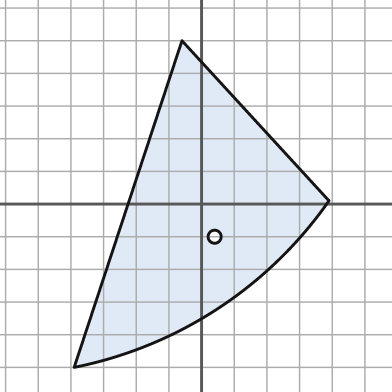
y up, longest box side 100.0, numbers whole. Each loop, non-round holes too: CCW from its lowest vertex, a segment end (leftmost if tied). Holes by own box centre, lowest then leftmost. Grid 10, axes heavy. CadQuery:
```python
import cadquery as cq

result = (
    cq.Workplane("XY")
    .moveTo(-39.0, -50.0)
    .threePointArc((5.0, -32.0), (39.0, 1.0))
    .lineTo(-6.0, 50.0)
    .close()
    .moveTo(4.0, -10.0)
    .circle(2.0)
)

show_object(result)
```